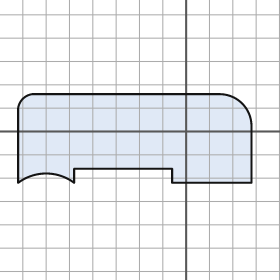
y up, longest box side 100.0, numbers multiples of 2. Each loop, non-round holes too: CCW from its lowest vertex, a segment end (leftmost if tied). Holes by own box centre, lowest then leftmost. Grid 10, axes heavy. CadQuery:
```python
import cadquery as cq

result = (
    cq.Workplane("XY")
    .moveTo(-72.0, -22.0)
    .threePointArc((-60.0, -18.0), (-48.0, -22.0))
    .lineTo(-48.0, -16.0)
    .lineTo(-6.0, -16.0)
    .lineTo(-6.0, -22.0)
    .lineTo(28.0, -22.0)
    .lineTo(28.0, 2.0)
    .threePointArc((24.0, 12.0), (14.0, 16.0))
    .lineTo(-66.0, 16.0)
    .threePointArc((-70.0, 14.0), (-72.0, 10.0))
    .close()
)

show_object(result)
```